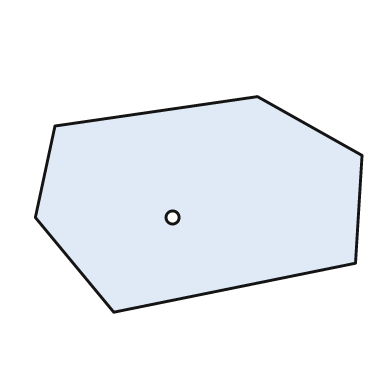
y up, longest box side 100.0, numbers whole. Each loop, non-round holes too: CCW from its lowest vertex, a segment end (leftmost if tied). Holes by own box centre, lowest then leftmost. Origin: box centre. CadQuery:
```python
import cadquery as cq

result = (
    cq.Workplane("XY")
    .moveTo(-26.0, -33.0)
    .lineTo(48.0, -18.0)
    .lineTo(50.0, 15.0)
    .lineTo(18.0, 33.0)
    .lineTo(-44.0, 24.0)
    .lineTo(-50.0, -4.0)
    .close()
    .moveTo(-8.0, -4.0)
    .circle(2.0)
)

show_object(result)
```